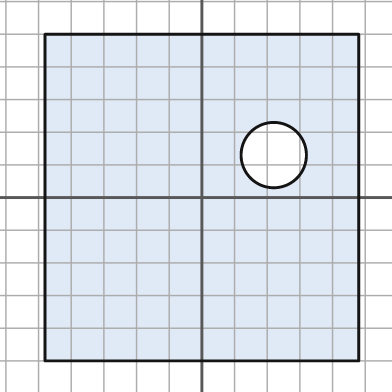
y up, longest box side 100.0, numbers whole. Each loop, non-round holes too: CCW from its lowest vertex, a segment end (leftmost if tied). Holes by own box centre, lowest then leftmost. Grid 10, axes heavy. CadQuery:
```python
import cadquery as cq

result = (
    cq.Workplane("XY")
    .moveTo(-48.0, -50.0)
    .lineTo(48.0, -50.0)
    .lineTo(48.0, 50.0)
    .lineTo(-48.0, 50.0)
    .close()
    .moveTo(22.0, 13.0)
    .circle(10.0)
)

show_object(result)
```